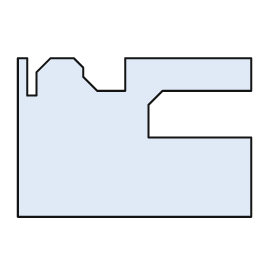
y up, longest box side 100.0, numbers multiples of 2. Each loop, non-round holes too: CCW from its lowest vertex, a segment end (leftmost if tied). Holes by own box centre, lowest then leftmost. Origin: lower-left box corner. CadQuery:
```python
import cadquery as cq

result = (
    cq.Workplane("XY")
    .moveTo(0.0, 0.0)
    .lineTo(100.0, 0.0)
    .lineTo(100.0, 34.0)
    .lineTo(56.0, 34.0)
    .lineTo(56.0, 48.0)
    .lineTo(62.0, 54.0)
    .lineTo(100.0, 54.0)
    .lineTo(100.0, 68.0)
    .lineTo(46.0, 68.0)
    .lineTo(46.0, 54.0)
    .lineTo(34.0, 54.0)
    .lineTo(28.0, 60.0)
    .lineTo(28.0, 64.0)
    .lineTo(24.0, 68.0)
    .lineTo(14.0, 68.0)
    .lineTo(8.0, 62.0)
    .lineTo(8.0, 52.0)
    .lineTo(4.0, 52.0)
    .lineTo(4.0, 68.0)
    .lineTo(0.0, 68.0)
    .close()
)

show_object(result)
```